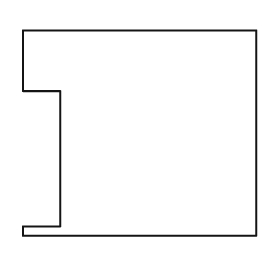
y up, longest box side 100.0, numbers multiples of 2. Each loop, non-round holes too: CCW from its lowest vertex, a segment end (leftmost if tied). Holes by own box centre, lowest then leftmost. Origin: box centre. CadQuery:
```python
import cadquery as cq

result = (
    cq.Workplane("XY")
    .moveTo(-50.0, -44.0)
    .lineTo(50.0, -44.0)
    .lineTo(50.0, 44.0)
    .lineTo(-50.0, 44.0)
    .lineTo(-50.0, 18.0)
    .lineTo(-34.0, 18.0)
    .lineTo(-34.0, -40.0)
    .lineTo(-50.0, -40.0)
    .close()
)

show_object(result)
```